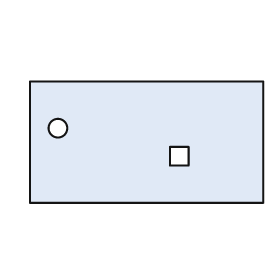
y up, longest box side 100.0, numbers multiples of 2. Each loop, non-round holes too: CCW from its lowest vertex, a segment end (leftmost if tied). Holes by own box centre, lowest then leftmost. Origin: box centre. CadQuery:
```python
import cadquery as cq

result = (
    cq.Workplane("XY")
    .moveTo(-50.0, -26.0)
    .lineTo(50.0, -26.0)
    .lineTo(50.0, 26.0)
    .lineTo(-50.0, 26.0)
    .close()
    .moveTo(10.0, -10.0)
    .lineTo(18.0, -10.0)
    .lineTo(18.0, -2.0)
    .lineTo(10.0, -2.0)
    .close()
    .moveTo(-38.0, 6.0)
    .circle(4.0)
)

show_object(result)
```